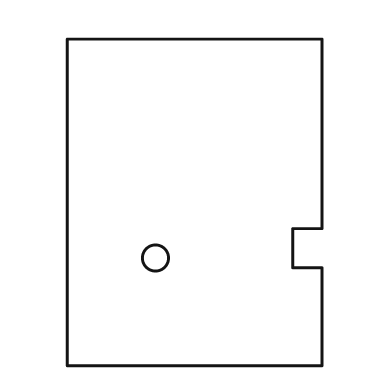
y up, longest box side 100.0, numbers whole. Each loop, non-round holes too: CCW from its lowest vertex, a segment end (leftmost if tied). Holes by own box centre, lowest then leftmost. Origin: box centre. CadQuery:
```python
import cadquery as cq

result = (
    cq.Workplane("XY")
    .moveTo(-39.0, -50.0)
    .lineTo(39.0, -50.0)
    .lineTo(39.0, -20.0)
    .lineTo(30.0, -20.0)
    .lineTo(30.0, -8.0)
    .lineTo(39.0, -8.0)
    .lineTo(39.0, 50.0)
    .lineTo(-39.0, 50.0)
    .close()
    .moveTo(-12.0, -17.0)
    .circle(4.0)
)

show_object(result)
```